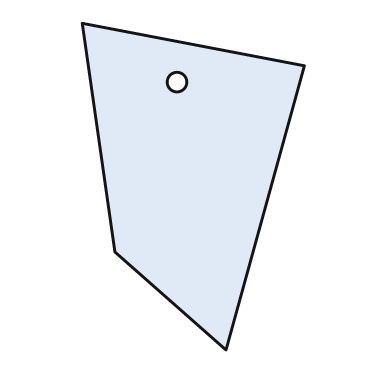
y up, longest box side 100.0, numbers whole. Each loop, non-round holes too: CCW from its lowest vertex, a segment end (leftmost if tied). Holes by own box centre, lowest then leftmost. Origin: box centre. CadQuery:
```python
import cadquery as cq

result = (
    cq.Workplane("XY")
    .moveTo(10.0, -50.0)
    .lineTo(34.0, 37.0)
    .lineTo(-34.0, 50.0)
    .lineTo(-24.0, -20.0)
    .close()
    .moveTo(-5.0, 32.0)
    .circle(3.0)
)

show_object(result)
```